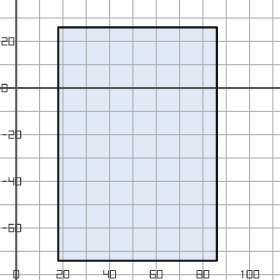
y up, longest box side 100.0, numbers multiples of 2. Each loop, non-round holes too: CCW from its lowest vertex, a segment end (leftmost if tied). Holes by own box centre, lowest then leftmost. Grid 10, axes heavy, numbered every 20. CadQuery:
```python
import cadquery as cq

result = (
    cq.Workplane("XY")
    .moveTo(18.0, -74.0)
    .lineTo(86.0, -74.0)
    .lineTo(86.0, 26.0)
    .lineTo(18.0, 26.0)
    .close()
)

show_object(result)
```